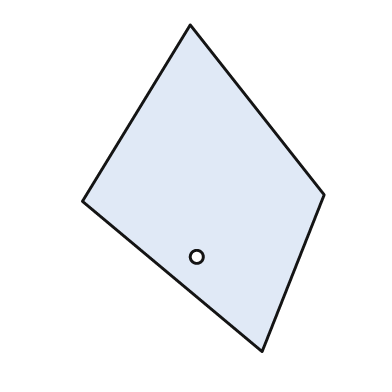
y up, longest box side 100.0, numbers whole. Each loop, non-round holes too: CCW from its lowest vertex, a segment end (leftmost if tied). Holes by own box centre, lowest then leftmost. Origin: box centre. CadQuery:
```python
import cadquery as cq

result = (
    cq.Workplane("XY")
    .moveTo(18.0, -50.0)
    .lineTo(37.0, -2.0)
    .lineTo(-4.0, 50.0)
    .lineTo(-37.0, -4.0)
    .close()
    .moveTo(-2.0, -21.0)
    .circle(2.0)
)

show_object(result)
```